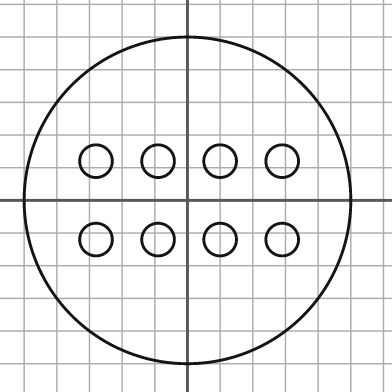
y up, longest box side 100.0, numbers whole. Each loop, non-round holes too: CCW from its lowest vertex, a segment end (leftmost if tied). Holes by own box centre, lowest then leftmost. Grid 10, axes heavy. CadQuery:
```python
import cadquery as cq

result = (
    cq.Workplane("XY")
    .moveTo(0.0, 0.0)
    .circle(50.0)
    .moveTo(-28.0, -12.0)
    .circle(5.0)
    .moveTo(-9.0, -12.0)
    .circle(5.0)
    .moveTo(10.0, -12.0)
    .circle(5.0)
    .moveTo(29.0, -12.0)
    .circle(5.0)
    .moveTo(-28.0, 12.0)
    .circle(5.0)
    .moveTo(-9.0, 12.0)
    .circle(5.0)
    .moveTo(10.0, 12.0)
    .circle(5.0)
    .moveTo(29.0, 12.0)
    .circle(5.0)
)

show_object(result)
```